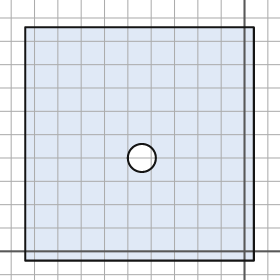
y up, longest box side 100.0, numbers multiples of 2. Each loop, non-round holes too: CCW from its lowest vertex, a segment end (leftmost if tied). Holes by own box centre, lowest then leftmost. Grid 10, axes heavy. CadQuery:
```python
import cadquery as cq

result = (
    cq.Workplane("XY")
    .moveTo(-94.0, -4.0)
    .lineTo(4.0, -4.0)
    .lineTo(4.0, 96.0)
    .lineTo(-94.0, 96.0)
    .close()
    .moveTo(-44.0, 40.0)
    .circle(6.0)
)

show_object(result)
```